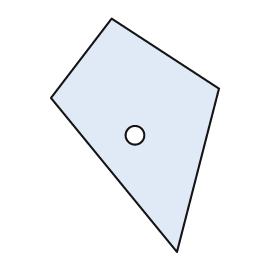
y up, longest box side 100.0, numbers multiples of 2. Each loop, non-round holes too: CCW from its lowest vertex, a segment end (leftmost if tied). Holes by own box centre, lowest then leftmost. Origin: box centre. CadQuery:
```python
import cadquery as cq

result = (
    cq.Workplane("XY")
    .moveTo(18.0, -50.0)
    .lineTo(36.0, 20.0)
    .lineTo(-10.0, 50.0)
    .lineTo(-36.0, 16.0)
    .close()
    .moveTo(0.0, 0.0)
    .circle(4.0)
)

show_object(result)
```